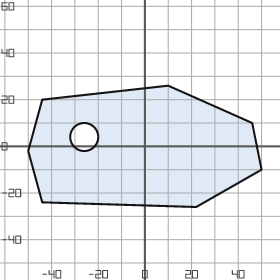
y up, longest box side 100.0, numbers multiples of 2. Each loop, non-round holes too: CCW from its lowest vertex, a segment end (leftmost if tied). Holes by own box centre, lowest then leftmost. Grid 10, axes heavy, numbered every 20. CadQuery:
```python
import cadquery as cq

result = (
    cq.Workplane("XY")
    .moveTo(22.0, -26.0)
    .lineTo(50.0, -10.0)
    .lineTo(46.0, 10.0)
    .lineTo(10.0, 26.0)
    .lineTo(-44.0, 20.0)
    .lineTo(-50.0, -2.0)
    .lineTo(-44.0, -24.0)
    .close()
    .moveTo(-26.0, 4.0)
    .circle(6.0)
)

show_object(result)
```